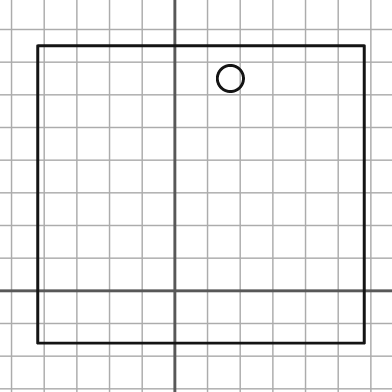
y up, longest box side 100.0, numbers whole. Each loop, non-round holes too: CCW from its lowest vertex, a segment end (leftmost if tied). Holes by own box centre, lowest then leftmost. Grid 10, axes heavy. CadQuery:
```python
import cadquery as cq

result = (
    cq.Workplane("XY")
    .moveTo(-42.0, -16.0)
    .lineTo(58.0, -16.0)
    .lineTo(58.0, 75.0)
    .lineTo(-42.0, 75.0)
    .close()
    .moveTo(17.0, 65.0)
    .circle(4.0)
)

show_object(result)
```